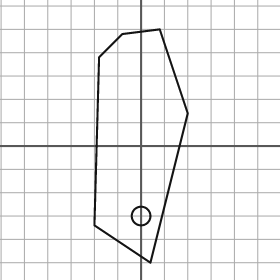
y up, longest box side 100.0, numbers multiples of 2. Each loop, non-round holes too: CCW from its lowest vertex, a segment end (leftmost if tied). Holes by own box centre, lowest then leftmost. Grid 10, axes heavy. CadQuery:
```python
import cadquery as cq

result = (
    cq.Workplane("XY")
    .moveTo(4.0, -50.0)
    .lineTo(20.0, 14.0)
    .lineTo(8.0, 50.0)
    .lineTo(-8.0, 48.0)
    .lineTo(-18.0, 38.0)
    .lineTo(-20.0, -34.0)
    .close()
    .moveTo(0.0, -30.0)
    .circle(4.0)
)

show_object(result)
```